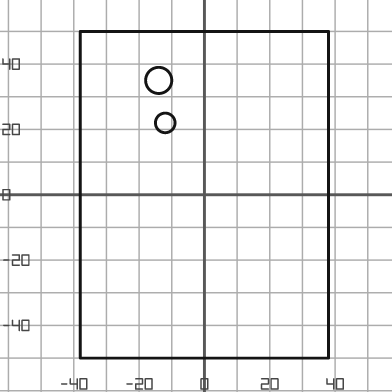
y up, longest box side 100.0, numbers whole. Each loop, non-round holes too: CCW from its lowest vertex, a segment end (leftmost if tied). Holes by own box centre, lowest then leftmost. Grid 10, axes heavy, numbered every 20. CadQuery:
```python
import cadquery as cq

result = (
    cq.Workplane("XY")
    .moveTo(-38.0, -50.0)
    .lineTo(38.0, -50.0)
    .lineTo(38.0, 50.0)
    .lineTo(-38.0, 50.0)
    .close()
    .moveTo(-12.0, 22.0)
    .circle(3.0)
    .moveTo(-14.0, 35.0)
    .circle(4.0)
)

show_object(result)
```